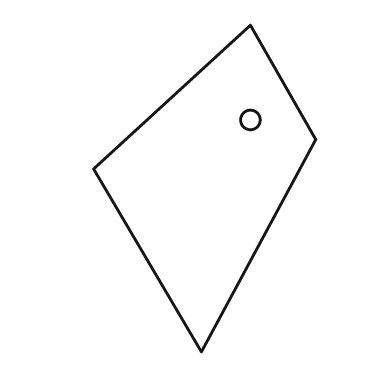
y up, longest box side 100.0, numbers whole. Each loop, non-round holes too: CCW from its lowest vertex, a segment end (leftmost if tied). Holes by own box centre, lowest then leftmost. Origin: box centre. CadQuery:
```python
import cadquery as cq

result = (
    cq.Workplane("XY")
    .moveTo(-1.0, -50.0)
    .lineTo(34.0, 15.0)
    .lineTo(14.0, 50.0)
    .lineTo(-34.0, 6.0)
    .close()
    .moveTo(14.0, 21.0)
    .circle(3.0)
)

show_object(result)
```